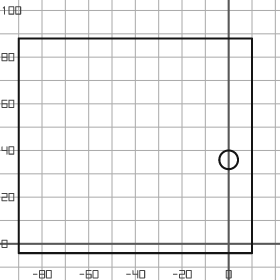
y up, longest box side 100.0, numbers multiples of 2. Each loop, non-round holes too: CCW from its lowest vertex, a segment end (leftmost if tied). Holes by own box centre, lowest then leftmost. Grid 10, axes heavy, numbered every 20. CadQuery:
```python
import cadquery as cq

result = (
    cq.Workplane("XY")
    .moveTo(-90.0, -4.0)
    .lineTo(10.0, -4.0)
    .lineTo(10.0, 88.0)
    .lineTo(-90.0, 88.0)
    .close()
    .moveTo(0.0, 36.0)
    .circle(4.0)
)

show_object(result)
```